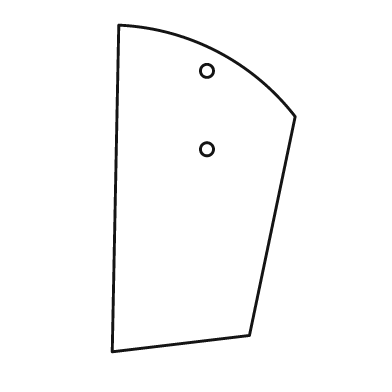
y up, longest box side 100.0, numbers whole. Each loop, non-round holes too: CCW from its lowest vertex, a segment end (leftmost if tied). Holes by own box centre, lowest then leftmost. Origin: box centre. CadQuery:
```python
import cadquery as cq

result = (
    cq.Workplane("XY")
    .moveTo(-28.0, -50.0)
    .lineTo(14.0, -45.0)
    .lineTo(28.0, 22.0)
    .threePointArc((4.0, 42.0), (-26.0, 50.0))
    .close()
    .moveTo(1.0, 12.0)
    .circle(2.0)
    .moveTo(1.0, 36.0)
    .circle(2.0)
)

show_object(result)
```